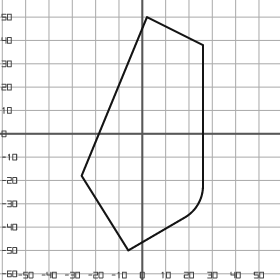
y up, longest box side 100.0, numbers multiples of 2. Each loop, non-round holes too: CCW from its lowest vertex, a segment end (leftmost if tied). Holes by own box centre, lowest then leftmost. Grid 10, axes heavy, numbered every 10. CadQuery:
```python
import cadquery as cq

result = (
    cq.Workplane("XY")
    .moveTo(-6.0, -50.0)
    .lineTo(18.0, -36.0)
    .threePointArc((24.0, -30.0), (26.0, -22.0))
    .lineTo(26.0, 38.0)
    .lineTo(2.0, 50.0)
    .lineTo(-26.0, -18.0)
    .close()
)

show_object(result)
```